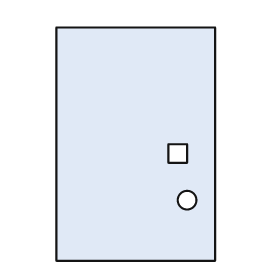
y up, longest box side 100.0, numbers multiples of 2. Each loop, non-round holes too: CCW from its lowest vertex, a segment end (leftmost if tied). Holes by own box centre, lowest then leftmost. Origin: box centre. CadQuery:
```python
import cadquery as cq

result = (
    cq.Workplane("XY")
    .moveTo(-34.0, -50.0)
    .lineTo(34.0, -50.0)
    .lineTo(34.0, 50.0)
    .lineTo(-34.0, 50.0)
    .close()
    .moveTo(22.0, -24.0)
    .circle(4.0)
    .moveTo(14.0, -8.0)
    .lineTo(22.0, -8.0)
    .lineTo(22.0, 0.0)
    .lineTo(14.0, 0.0)
    .close()
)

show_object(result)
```